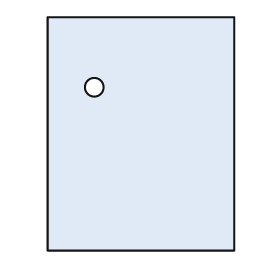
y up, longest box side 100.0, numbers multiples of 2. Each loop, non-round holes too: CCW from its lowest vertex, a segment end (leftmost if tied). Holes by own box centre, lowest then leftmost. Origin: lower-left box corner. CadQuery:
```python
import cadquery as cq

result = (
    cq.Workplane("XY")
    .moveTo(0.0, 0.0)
    .lineTo(80.0, 0.0)
    .lineTo(80.0, 100.0)
    .lineTo(0.0, 100.0)
    .close()
    .moveTo(20.0, 70.0)
    .circle(4.0)
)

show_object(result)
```